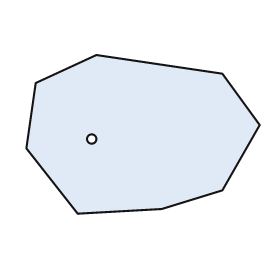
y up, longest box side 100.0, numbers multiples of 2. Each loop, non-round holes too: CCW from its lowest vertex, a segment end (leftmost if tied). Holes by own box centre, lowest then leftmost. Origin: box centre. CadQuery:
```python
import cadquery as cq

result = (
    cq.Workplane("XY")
    .moveTo(-28.0, -34.0)
    .lineTo(8.0, -32.0)
    .lineTo(34.0, -24.0)
    .lineTo(50.0, 4.0)
    .lineTo(34.0, 26.0)
    .lineTo(-20.0, 34.0)
    .lineTo(-46.0, 22.0)
    .lineTo(-50.0, -6.0)
    .close()
    .moveTo(-22.0, -2.0)
    .circle(2.0)
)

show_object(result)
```